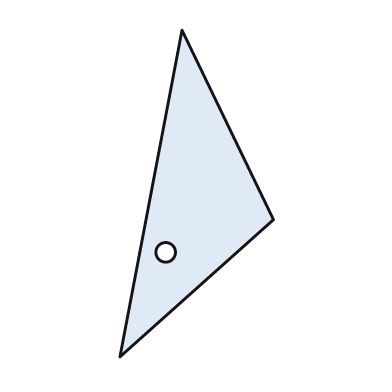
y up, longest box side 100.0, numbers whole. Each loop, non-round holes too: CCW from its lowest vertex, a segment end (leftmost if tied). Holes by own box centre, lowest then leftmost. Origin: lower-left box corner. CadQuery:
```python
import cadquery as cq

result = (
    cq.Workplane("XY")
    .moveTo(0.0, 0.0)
    .lineTo(47.0, 42.0)
    .lineTo(19.0, 100.0)
    .close()
    .moveTo(14.0, 32.0)
    .circle(3.0)
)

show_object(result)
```